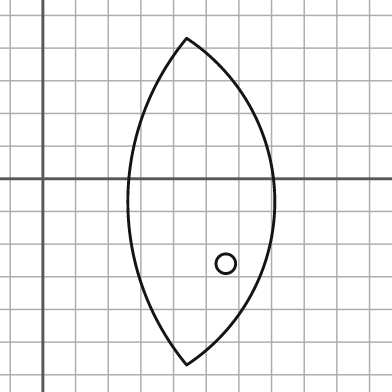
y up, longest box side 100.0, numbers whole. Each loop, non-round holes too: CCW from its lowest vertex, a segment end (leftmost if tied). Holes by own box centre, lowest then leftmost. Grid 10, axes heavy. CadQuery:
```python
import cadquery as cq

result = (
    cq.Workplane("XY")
    .moveTo(44.0, -57.0)
    .threePointArc((71.0, -7.0), (44.0, 43.0))
    .threePointArc((26.0, -7.0), (44.0, -57.0))
    .close()
    .moveTo(56.0, -26.0)
    .circle(3.0)
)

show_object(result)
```